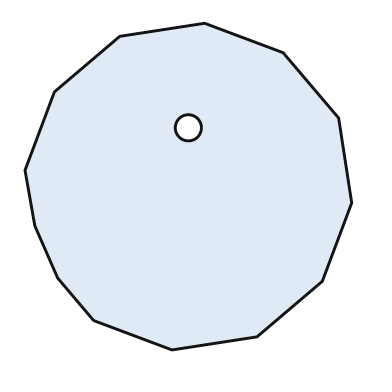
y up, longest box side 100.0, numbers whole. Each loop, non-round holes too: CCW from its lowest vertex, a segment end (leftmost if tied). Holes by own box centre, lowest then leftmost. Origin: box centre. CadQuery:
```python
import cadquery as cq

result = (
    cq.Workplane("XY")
    .moveTo(-5.0, -50.0)
    .lineTo(21.0, -46.0)
    .lineTo(41.0, -29.0)
    .lineTo(50.0, -5.0)
    .lineTo(46.0, 21.0)
    .lineTo(29.0, 41.0)
    .lineTo(5.0, 50.0)
    .lineTo(-21.0, 46.0)
    .lineTo(-41.0, 29.0)
    .lineTo(-50.0, 5.0)
    .lineTo(-47.0, -12.0)
    .lineTo(-40.0, -28.0)
    .lineTo(-29.0, -41.0)
    .close()
    .moveTo(0.0, 18.0)
    .circle(4.0)
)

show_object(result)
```